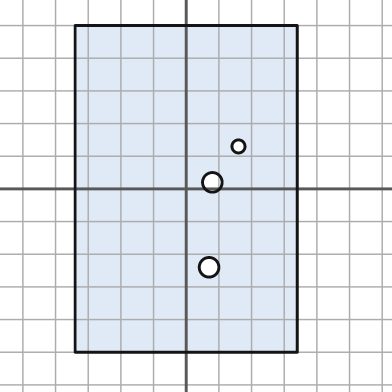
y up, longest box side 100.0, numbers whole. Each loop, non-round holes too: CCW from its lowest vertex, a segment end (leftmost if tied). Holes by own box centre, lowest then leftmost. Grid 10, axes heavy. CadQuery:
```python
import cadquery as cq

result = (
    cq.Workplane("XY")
    .moveTo(-34.0, -50.0)
    .lineTo(34.0, -50.0)
    .lineTo(34.0, 50.0)
    .lineTo(-34.0, 50.0)
    .close()
    .moveTo(7.0, -24.0)
    .circle(3.0)
    .moveTo(8.0, 2.0)
    .circle(3.0)
    .moveTo(16.0, 13.0)
    .circle(2.0)
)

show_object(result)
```